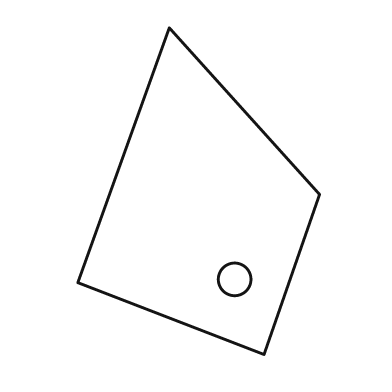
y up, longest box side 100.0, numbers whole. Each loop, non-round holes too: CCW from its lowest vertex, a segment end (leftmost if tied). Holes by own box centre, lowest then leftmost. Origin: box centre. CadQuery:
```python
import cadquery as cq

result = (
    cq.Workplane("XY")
    .moveTo(20.0, -50.0)
    .lineTo(37.0, -1.0)
    .lineTo(-9.0, 50.0)
    .lineTo(-37.0, -28.0)
    .close()
    .moveTo(11.0, -27.0)
    .circle(5.0)
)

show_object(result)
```